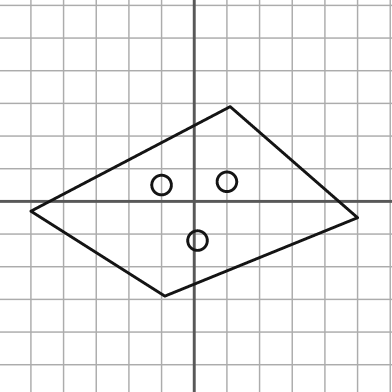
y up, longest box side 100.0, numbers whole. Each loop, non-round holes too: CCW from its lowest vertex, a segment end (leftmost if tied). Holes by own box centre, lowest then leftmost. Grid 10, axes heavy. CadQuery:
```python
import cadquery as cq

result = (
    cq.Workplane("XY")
    .moveTo(-9.0, -29.0)
    .lineTo(50.0, -5.0)
    .lineTo(11.0, 29.0)
    .lineTo(-50.0, -3.0)
    .close()
    .moveTo(1.0, -12.0)
    .circle(3.0)
    .moveTo(-10.0, 5.0)
    .circle(3.0)
    .moveTo(10.0, 6.0)
    .circle(3.0)
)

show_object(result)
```